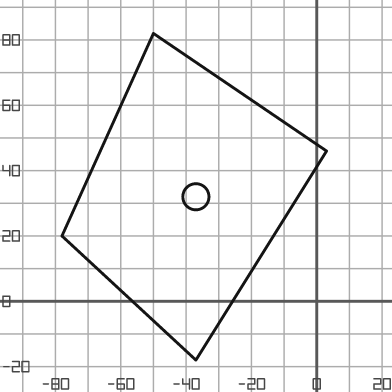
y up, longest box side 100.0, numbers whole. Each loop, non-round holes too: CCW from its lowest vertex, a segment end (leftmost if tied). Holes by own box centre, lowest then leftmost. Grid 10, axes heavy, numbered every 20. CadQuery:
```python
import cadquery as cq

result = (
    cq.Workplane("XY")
    .moveTo(-37.0, -18.0)
    .lineTo(3.0, 46.0)
    .lineTo(-50.0, 82.0)
    .lineTo(-78.0, 20.0)
    .close()
    .moveTo(-37.0, 32.0)
    .circle(4.0)
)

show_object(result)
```